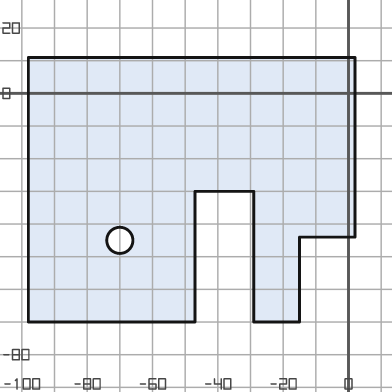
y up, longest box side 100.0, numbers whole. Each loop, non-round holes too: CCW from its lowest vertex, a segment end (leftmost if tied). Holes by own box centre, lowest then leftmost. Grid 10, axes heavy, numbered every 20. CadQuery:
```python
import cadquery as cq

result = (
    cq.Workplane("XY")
    .moveTo(-98.0, -70.0)
    .lineTo(-47.0, -70.0)
    .lineTo(-47.0, -30.0)
    .lineTo(-29.0, -30.0)
    .lineTo(-29.0, -70.0)
    .lineTo(-15.0, -70.0)
    .lineTo(-15.0, -44.0)
    .lineTo(2.0, -44.0)
    .lineTo(2.0, 11.0)
    .lineTo(-98.0, 11.0)
    .close()
    .moveTo(-70.0, -45.0)
    .circle(4.0)
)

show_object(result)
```